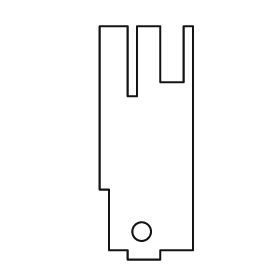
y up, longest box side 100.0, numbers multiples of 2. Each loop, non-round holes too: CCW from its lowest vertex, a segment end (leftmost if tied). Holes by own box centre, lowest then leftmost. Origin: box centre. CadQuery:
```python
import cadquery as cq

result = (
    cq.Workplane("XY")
    .moveTo(-8.0, -50.0)
    .lineTo(6.0, -50.0)
    .lineTo(6.0, -46.0)
    .lineTo(20.0, -46.0)
    .lineTo(20.0, 50.0)
    .lineTo(16.0, 50.0)
    .lineTo(16.0, 26.0)
    .lineTo(6.0, 26.0)
    .lineTo(6.0, 50.0)
    .lineTo(-4.0, 50.0)
    .lineTo(-4.0, 20.0)
    .lineTo(-8.0, 20.0)
    .lineTo(-8.0, 50.0)
    .lineTo(-20.0, 50.0)
    .lineTo(-20.0, -20.0)
    .lineTo(-16.0, -20.0)
    .lineTo(-16.0, -46.0)
    .lineTo(-8.0, -46.0)
    .close()
    .moveTo(-2.0, -38.0)
    .circle(4.0)
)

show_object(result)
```